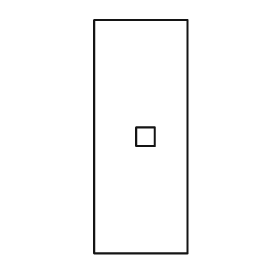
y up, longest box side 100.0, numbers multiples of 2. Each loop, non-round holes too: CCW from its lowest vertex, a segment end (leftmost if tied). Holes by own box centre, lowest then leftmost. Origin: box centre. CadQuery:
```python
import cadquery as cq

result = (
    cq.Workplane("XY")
    .moveTo(-20.0, -50.0)
    .lineTo(20.0, -50.0)
    .lineTo(20.0, 50.0)
    .lineTo(-20.0, 50.0)
    .close()
    .moveTo(-2.0, -4.0)
    .lineTo(6.0, -4.0)
    .lineTo(6.0, 4.0)
    .lineTo(-2.0, 4.0)
    .close()
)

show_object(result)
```